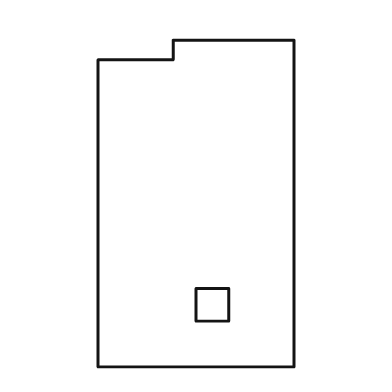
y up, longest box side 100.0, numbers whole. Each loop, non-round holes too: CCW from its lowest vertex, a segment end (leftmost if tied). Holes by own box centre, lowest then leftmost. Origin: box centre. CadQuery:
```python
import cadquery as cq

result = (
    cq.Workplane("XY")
    .moveTo(-30.0, -50.0)
    .lineTo(30.0, -50.0)
    .lineTo(30.0, 50.0)
    .lineTo(-7.0, 50.0)
    .lineTo(-7.0, 44.0)
    .lineTo(-30.0, 44.0)
    .close()
    .moveTo(0.0, -36.0)
    .lineTo(10.0, -36.0)
    .lineTo(10.0, -26.0)
    .lineTo(0.0, -26.0)
    .close()
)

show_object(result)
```